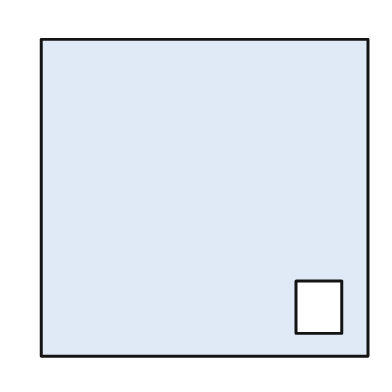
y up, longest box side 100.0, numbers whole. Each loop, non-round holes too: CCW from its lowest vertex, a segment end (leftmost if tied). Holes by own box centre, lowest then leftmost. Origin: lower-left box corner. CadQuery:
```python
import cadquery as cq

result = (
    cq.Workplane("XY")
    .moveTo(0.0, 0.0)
    .lineTo(100.0, 0.0)
    .lineTo(100.0, 97.0)
    .lineTo(0.0, 97.0)
    .close()
    .moveTo(78.0, 7.0)
    .lineTo(92.0, 7.0)
    .lineTo(92.0, 23.0)
    .lineTo(78.0, 23.0)
    .close()
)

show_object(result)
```